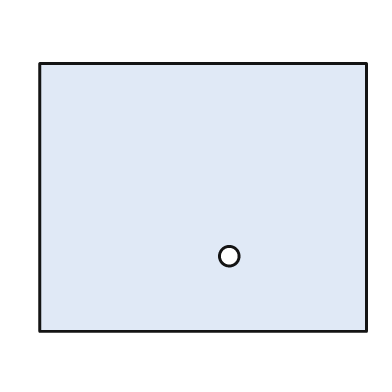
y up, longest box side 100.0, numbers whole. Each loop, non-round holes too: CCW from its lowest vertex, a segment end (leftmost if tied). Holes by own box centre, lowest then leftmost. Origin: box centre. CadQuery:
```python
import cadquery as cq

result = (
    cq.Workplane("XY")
    .moveTo(-50.0, -41.0)
    .lineTo(50.0, -41.0)
    .lineTo(50.0, 41.0)
    .lineTo(-50.0, 41.0)
    .close()
    .moveTo(8.0, -18.0)
    .circle(3.0)
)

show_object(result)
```